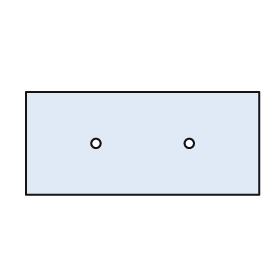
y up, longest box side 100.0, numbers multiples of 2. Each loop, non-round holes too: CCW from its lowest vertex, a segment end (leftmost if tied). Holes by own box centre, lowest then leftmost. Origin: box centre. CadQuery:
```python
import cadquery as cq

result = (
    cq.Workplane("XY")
    .moveTo(-50.0, -22.0)
    .lineTo(50.0, -22.0)
    .lineTo(50.0, 22.0)
    .lineTo(-50.0, 22.0)
    .close()
    .moveTo(-20.0, 0.0)
    .circle(2.0)
    .moveTo(20.0, 0.0)
    .circle(2.0)
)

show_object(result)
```